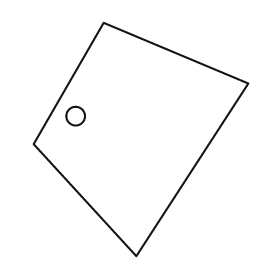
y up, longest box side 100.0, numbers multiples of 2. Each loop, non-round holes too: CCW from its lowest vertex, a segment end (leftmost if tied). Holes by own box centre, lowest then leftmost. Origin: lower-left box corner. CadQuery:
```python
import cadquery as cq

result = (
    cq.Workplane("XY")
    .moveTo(44.0, 0.0)
    .lineTo(92.0, 74.0)
    .lineTo(30.0, 100.0)
    .lineTo(0.0, 48.0)
    .close()
    .moveTo(18.0, 60.0)
    .circle(4.0)
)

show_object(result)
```